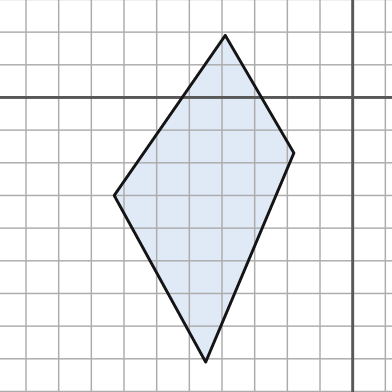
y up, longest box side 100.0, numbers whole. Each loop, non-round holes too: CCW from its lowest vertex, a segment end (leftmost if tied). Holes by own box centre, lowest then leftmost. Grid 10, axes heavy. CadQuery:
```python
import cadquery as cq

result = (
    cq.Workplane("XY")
    .moveTo(-45.0, -81.0)
    .lineTo(-18.0, -17.0)
    .lineTo(-39.0, 19.0)
    .lineTo(-73.0, -30.0)
    .close()
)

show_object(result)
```